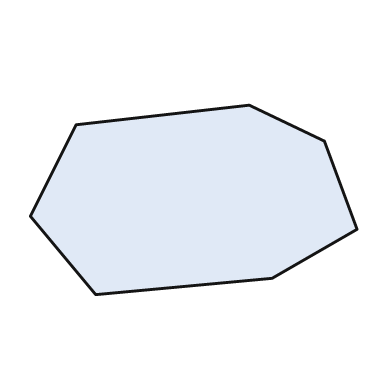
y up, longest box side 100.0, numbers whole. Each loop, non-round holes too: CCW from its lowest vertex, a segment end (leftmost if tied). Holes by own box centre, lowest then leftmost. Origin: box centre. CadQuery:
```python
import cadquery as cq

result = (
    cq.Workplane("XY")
    .moveTo(-30.0, -29.0)
    .lineTo(24.0, -24.0)
    .lineTo(50.0, -9.0)
    .lineTo(40.0, 18.0)
    .lineTo(17.0, 29.0)
    .lineTo(-36.0, 23.0)
    .lineTo(-50.0, -5.0)
    .close()
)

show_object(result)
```